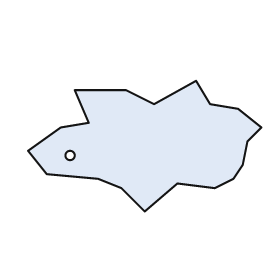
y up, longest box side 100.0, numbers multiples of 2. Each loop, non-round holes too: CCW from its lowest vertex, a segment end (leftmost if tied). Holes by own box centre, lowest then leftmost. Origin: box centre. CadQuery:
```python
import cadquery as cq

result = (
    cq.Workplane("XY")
    .moveTo(0.0, -28.0)
    .lineTo(14.0, -16.0)
    .lineTo(30.0, -18.0)
    .lineTo(38.0, -14.0)
    .lineTo(42.0, -8.0)
    .lineTo(44.0, 2.0)
    .lineTo(50.0, 8.0)
    .lineTo(40.0, 16.0)
    .lineTo(28.0, 18.0)
    .lineTo(22.0, 28.0)
    .lineTo(4.0, 18.0)
    .lineTo(-8.0, 24.0)
    .lineTo(-30.0, 24.0)
    .lineTo(-24.0, 10.0)
    .lineTo(-36.0, 8.0)
    .lineTo(-50.0, -2.0)
    .lineTo(-42.0, -12.0)
    .lineTo(-20.0, -14.0)
    .lineTo(-10.0, -18.0)
    .close()
    .moveTo(-32.0, -4.0)
    .circle(2.0)
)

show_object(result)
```